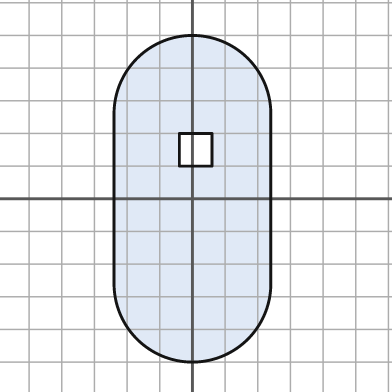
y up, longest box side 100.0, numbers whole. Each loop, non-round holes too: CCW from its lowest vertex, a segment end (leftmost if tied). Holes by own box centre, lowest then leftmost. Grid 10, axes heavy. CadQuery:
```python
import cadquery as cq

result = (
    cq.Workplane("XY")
    .moveTo(-24.0, -26.0)
    .threePointArc((0.0, -50.0), (24.0, -26.0))
    .lineTo(24.0, 26.0)
    .threePointArc((0.0, 50.0), (-24.0, 26.0))
    .close()
    .moveTo(-4.0, 10.0)
    .lineTo(6.0, 10.0)
    .lineTo(6.0, 20.0)
    .lineTo(-4.0, 20.0)
    .close()
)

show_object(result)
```